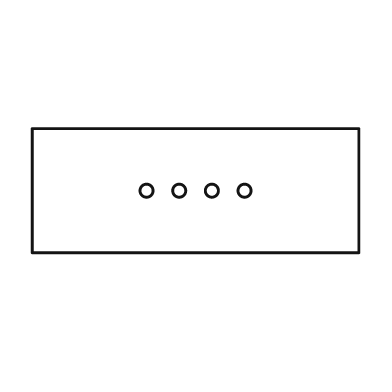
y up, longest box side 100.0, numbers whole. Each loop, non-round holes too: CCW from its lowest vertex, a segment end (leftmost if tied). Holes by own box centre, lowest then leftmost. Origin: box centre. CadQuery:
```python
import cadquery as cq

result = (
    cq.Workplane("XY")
    .moveTo(-50.0, -19.0)
    .lineTo(50.0, -19.0)
    .lineTo(50.0, 19.0)
    .lineTo(-50.0, 19.0)
    .close()
    .moveTo(-15.0, 0.0)
    .circle(2.0)
    .moveTo(-5.0, 0.0)
    .circle(2.0)
    .moveTo(5.0, 0.0)
    .circle(2.0)
    .moveTo(15.0, 0.0)
    .circle(2.0)
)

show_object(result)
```